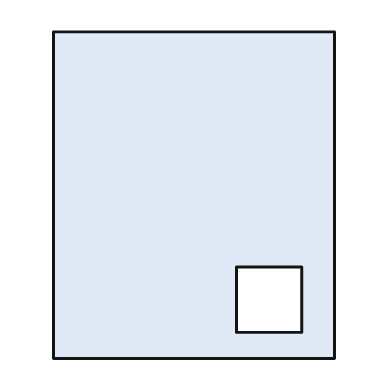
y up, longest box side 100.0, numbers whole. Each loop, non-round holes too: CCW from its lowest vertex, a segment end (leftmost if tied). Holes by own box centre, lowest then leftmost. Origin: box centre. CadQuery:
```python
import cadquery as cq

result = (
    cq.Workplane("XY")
    .moveTo(-43.0, -50.0)
    .lineTo(43.0, -50.0)
    .lineTo(43.0, 50.0)
    .lineTo(-43.0, 50.0)
    .close()
    .moveTo(13.0, -42.0)
    .lineTo(33.0, -42.0)
    .lineTo(33.0, -22.0)
    .lineTo(13.0, -22.0)
    .close()
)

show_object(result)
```